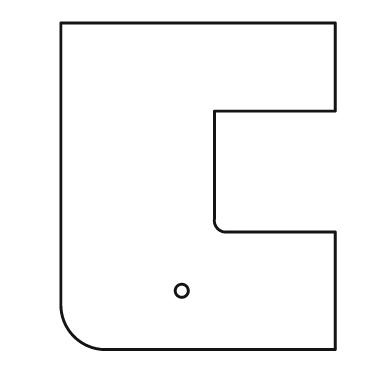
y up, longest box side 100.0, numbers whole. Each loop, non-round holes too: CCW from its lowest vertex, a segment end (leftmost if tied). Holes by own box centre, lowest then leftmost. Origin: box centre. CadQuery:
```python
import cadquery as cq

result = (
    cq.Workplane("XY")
    .moveTo(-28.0, -50.0)
    .lineTo(42.0, -50.0)
    .lineTo(42.0, -14.0)
    .lineTo(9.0, -14.0)
    .threePointArc((6.0, -13.0), (5.0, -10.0))
    .lineTo(5.0, 23.0)
    .lineTo(42.0, 23.0)
    .lineTo(42.0, 50.0)
    .lineTo(-42.0, 50.0)
    .lineTo(-42.0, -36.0)
    .threePointArc((-38.0, -46.0), (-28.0, -50.0))
    .close()
    .moveTo(-5.0, -32.0)
    .circle(2.0)
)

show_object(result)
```